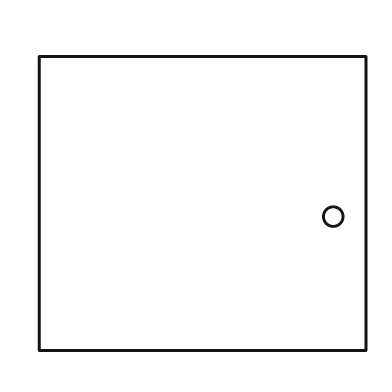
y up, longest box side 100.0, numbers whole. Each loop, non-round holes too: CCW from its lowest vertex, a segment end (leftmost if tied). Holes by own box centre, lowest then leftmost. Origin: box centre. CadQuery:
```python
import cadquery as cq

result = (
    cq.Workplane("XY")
    .moveTo(-50.0, -45.0)
    .lineTo(50.0, -45.0)
    .lineTo(50.0, 45.0)
    .lineTo(-50.0, 45.0)
    .close()
    .moveTo(40.0, -4.0)
    .circle(3.0)
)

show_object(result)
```